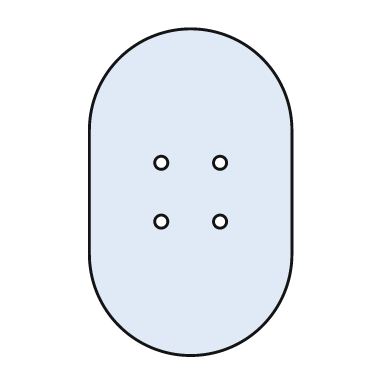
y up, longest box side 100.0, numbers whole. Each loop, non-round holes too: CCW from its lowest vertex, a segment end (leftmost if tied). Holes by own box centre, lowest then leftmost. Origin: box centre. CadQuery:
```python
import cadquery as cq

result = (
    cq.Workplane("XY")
    .moveTo(-31.0, -19.0)
    .threePointArc((0.0, -50.0), (31.0, -19.0))
    .lineTo(31.0, 19.0)
    .threePointArc((0.0, 50.0), (-31.0, 19.0))
    .close()
    .moveTo(-9.0, -9.0)
    .circle(2.0)
    .moveTo(9.0, -9.0)
    .circle(2.0)
    .moveTo(-9.0, 9.0)
    .circle(2.0)
    .moveTo(9.0, 9.0)
    .circle(2.0)
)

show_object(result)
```